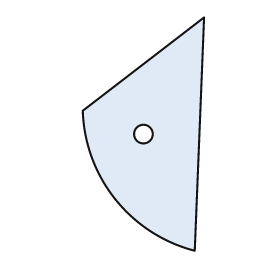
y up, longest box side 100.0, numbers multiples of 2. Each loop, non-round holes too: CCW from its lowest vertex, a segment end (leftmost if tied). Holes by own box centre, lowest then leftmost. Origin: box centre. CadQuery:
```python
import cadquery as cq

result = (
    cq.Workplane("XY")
    .moveTo(22.0, -50.0)
    .lineTo(26.0, 50.0)
    .lineTo(-26.0, 10.0)
    .threePointArc((-12.0, -28.0), (22.0, -50.0))
    .close()
    .moveTo(0.0, 0.0)
    .circle(4.0)
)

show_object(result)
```